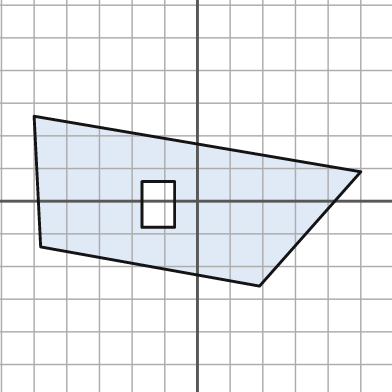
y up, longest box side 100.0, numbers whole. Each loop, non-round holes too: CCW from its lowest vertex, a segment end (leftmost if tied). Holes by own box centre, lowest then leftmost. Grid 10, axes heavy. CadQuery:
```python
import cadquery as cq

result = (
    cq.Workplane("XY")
    .moveTo(19.0, -26.0)
    .lineTo(50.0, 9.0)
    .lineTo(-50.0, 26.0)
    .lineTo(-48.0, -14.0)
    .close()
    .moveTo(-17.0, -8.0)
    .lineTo(-7.0, -8.0)
    .lineTo(-7.0, 6.0)
    .lineTo(-17.0, 6.0)
    .close()
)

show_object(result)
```